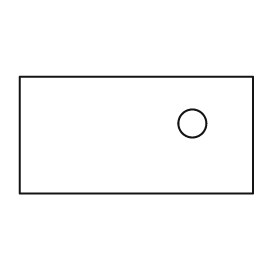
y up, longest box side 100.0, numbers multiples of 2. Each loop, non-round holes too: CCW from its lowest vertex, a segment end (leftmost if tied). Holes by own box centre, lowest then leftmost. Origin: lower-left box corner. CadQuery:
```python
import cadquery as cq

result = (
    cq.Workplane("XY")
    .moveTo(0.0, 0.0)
    .lineTo(100.0, 0.0)
    .lineTo(100.0, 50.0)
    .lineTo(0.0, 50.0)
    .close()
    .moveTo(74.0, 30.0)
    .circle(6.0)
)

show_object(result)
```